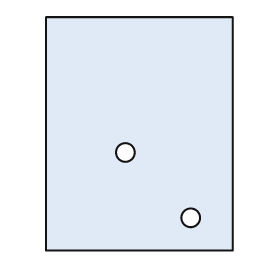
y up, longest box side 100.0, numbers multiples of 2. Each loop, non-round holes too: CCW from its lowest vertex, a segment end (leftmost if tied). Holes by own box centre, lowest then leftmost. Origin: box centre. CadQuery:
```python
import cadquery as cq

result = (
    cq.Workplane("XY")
    .moveTo(-40.0, -50.0)
    .lineTo(40.0, -50.0)
    .lineTo(40.0, 50.0)
    .lineTo(-40.0, 50.0)
    .close()
    .moveTo(22.0, -36.0)
    .circle(4.0)
    .moveTo(-6.0, -8.0)
    .circle(4.0)
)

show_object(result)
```